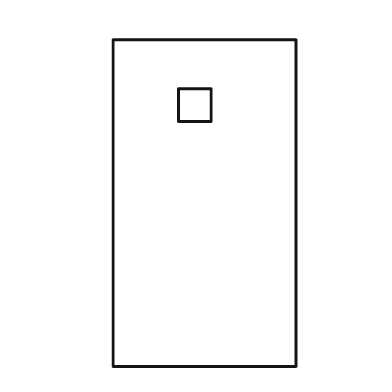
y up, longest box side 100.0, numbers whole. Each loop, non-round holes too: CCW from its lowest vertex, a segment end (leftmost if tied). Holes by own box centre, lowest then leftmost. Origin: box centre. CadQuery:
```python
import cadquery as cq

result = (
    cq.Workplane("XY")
    .moveTo(-28.0, -50.0)
    .lineTo(28.0, -50.0)
    .lineTo(28.0, 50.0)
    .lineTo(-28.0, 50.0)
    .close()
    .moveTo(-8.0, 25.0)
    .lineTo(2.0, 25.0)
    .lineTo(2.0, 35.0)
    .lineTo(-8.0, 35.0)
    .close()
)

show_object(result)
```